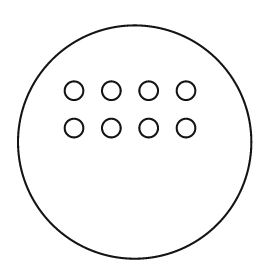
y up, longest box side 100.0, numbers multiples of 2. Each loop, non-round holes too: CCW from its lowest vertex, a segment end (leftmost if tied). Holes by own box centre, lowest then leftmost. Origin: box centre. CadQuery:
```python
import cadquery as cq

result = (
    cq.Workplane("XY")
    .moveTo(0.0, 0.0)
    .circle(50.0)
    .moveTo(-26.0, 6.0)
    .circle(4.0)
    .moveTo(-10.0, 6.0)
    .circle(4.0)
    .moveTo(6.0, 6.0)
    .circle(4.0)
    .moveTo(22.0, 6.0)
    .circle(4.0)
    .moveTo(-26.0, 22.0)
    .circle(4.0)
    .moveTo(-10.0, 22.0)
    .circle(4.0)
    .moveTo(6.0, 22.0)
    .circle(4.0)
    .moveTo(22.0, 22.0)
    .circle(4.0)
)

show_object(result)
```